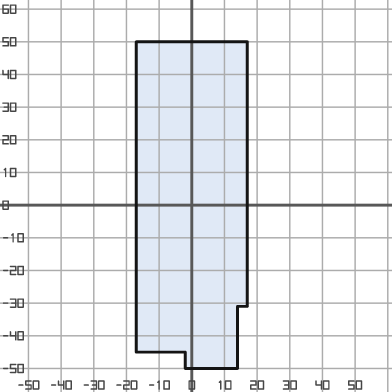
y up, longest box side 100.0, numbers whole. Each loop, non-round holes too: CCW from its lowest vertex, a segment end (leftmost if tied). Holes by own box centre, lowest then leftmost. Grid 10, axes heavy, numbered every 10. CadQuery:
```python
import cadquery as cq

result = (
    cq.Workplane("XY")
    .moveTo(-2.0, -50.0)
    .lineTo(14.0, -50.0)
    .lineTo(14.0, -31.0)
    .lineTo(17.0, -31.0)
    .lineTo(17.0, 50.0)
    .lineTo(-17.0, 50.0)
    .lineTo(-17.0, -45.0)
    .lineTo(-2.0, -45.0)
    .close()
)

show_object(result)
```